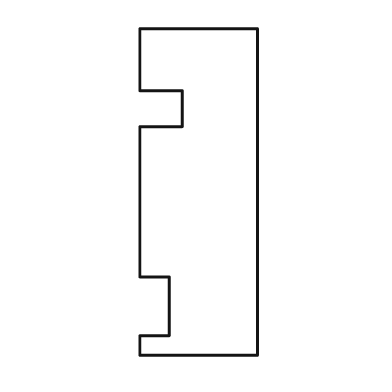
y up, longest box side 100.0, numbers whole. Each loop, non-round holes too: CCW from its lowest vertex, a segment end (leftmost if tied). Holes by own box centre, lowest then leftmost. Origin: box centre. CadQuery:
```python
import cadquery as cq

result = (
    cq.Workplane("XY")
    .moveTo(-18.0, -50.0)
    .lineTo(18.0, -50.0)
    .lineTo(18.0, 50.0)
    .lineTo(-18.0, 50.0)
    .lineTo(-18.0, 31.0)
    .lineTo(-5.0, 31.0)
    .lineTo(-5.0, 20.0)
    .lineTo(-18.0, 20.0)
    .lineTo(-18.0, -26.0)
    .lineTo(-9.0, -26.0)
    .lineTo(-9.0, -44.0)
    .lineTo(-18.0, -44.0)
    .close()
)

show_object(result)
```